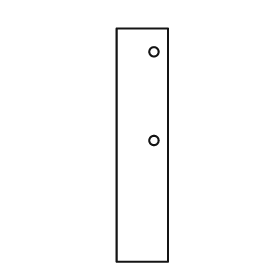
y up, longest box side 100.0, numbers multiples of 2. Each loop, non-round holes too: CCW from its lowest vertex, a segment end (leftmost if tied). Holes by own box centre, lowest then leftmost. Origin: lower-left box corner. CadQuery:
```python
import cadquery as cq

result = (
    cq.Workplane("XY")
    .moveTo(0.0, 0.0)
    .lineTo(22.0, 0.0)
    .lineTo(22.0, 100.0)
    .lineTo(0.0, 100.0)
    .close()
    .moveTo(16.0, 52.0)
    .circle(2.0)
    .moveTo(16.0, 90.0)
    .circle(2.0)
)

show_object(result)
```